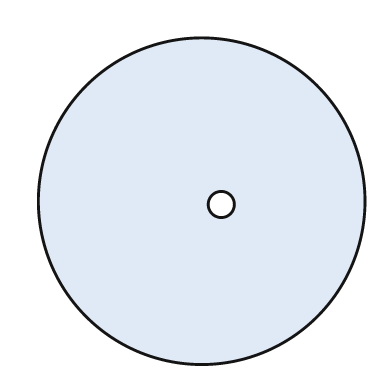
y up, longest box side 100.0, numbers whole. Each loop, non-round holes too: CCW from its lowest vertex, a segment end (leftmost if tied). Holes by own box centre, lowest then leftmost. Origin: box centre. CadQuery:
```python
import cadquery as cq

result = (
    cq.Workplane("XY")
    .moveTo(0.0, 0.0)
    .circle(50.0)
    .moveTo(6.0, -1.0)
    .circle(4.0)
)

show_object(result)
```